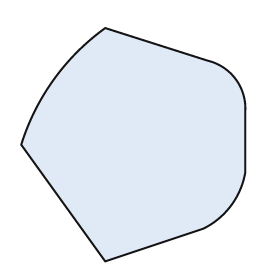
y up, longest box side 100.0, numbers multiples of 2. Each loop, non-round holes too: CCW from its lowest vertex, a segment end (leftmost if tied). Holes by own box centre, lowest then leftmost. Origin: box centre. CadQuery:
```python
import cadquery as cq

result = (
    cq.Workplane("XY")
    .moveTo(-12.0, -50.0)
    .lineTo(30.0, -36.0)
    .threePointArc((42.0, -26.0), (48.0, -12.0))
    .lineTo(48.0, 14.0)
    .threePointArc((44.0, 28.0), (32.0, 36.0))
    .lineTo(-12.0, 50.0)
    .threePointArc((-34.0, 28.0), (-48.0, 0.0))
    .close()
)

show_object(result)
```